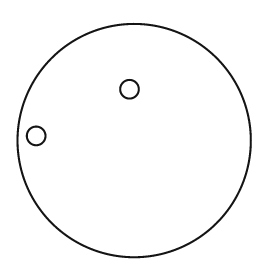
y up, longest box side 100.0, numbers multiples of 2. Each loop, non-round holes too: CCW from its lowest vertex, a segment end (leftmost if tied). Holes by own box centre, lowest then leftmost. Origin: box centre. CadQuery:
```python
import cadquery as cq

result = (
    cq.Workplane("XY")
    .moveTo(0.0, 0.0)
    .circle(50.0)
    .moveTo(-42.0, 2.0)
    .circle(4.0)
    .moveTo(-2.0, 22.0)
    .circle(4.0)
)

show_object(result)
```